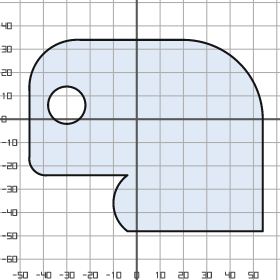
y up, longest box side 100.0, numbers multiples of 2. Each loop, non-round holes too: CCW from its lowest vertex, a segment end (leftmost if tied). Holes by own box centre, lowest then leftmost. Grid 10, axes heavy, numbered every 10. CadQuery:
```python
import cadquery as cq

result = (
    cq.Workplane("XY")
    .moveTo(-4.0, -48.0)
    .lineTo(54.0, -48.0)
    .lineTo(54.0, 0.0)
    .threePointArc((44.0, 24.0), (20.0, 34.0))
    .lineTo(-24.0, 34.0)
    .threePointArc((-40.0, 28.0), (-46.0, 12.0))
    .lineTo(-46.0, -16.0)
    .threePointArc((-44.0, -22.0), (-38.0, -24.0))
    .lineTo(-4.0, -24.0)
    .threePointArc((-10.0, -36.0), (-4.0, -48.0))
    .close()
    .moveTo(-30.0, 6.0)
    .circle(8.0)
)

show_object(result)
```